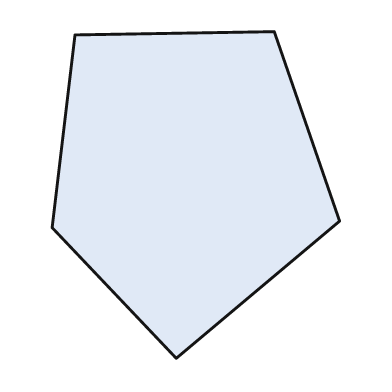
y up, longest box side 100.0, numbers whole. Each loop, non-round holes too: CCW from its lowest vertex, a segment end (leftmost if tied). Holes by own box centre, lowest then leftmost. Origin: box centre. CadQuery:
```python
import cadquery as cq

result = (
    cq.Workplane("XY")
    .moveTo(-6.0, -50.0)
    .lineTo(44.0, -8.0)
    .lineTo(24.0, 50.0)
    .lineTo(-37.0, 49.0)
    .lineTo(-44.0, -10.0)
    .close()
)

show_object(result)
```